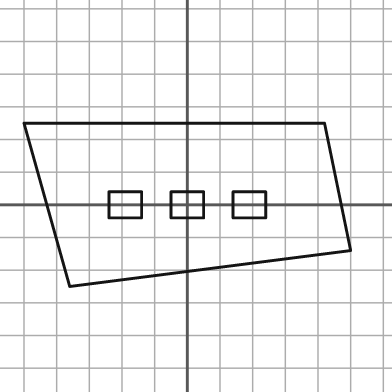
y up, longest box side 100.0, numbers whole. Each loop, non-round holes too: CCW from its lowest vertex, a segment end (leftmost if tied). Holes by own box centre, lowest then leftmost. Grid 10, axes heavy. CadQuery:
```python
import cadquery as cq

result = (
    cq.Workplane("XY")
    .moveTo(-36.0, -25.0)
    .lineTo(50.0, -14.0)
    .lineTo(42.0, 25.0)
    .lineTo(-50.0, 25.0)
    .close()
    .moveTo(-24.0, -4.0)
    .lineTo(-14.0, -4.0)
    .lineTo(-14.0, 4.0)
    .lineTo(-24.0, 4.0)
    .close()
    .moveTo(-5.0, -4.0)
    .lineTo(5.0, -4.0)
    .lineTo(5.0, 4.0)
    .lineTo(-5.0, 4.0)
    .close()
    .moveTo(14.0, -4.0)
    .lineTo(24.0, -4.0)
    .lineTo(24.0, 4.0)
    .lineTo(14.0, 4.0)
    .close()
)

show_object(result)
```